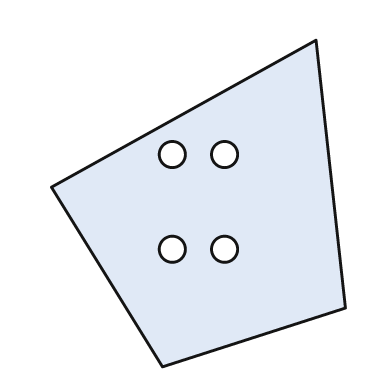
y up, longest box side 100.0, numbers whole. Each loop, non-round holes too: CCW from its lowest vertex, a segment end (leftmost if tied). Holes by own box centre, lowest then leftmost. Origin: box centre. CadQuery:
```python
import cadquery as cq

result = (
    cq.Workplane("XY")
    .moveTo(-11.0, -50.0)
    .lineTo(45.0, -32.0)
    .lineTo(36.0, 50.0)
    .lineTo(-45.0, 5.0)
    .close()
    .moveTo(-8.0, -14.0)
    .circle(4.0)
    .moveTo(8.0, -14.0)
    .circle(4.0)
    .moveTo(-8.0, 15.0)
    .circle(4.0)
    .moveTo(8.0, 15.0)
    .circle(4.0)
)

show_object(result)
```